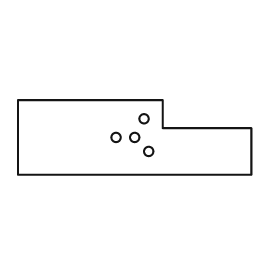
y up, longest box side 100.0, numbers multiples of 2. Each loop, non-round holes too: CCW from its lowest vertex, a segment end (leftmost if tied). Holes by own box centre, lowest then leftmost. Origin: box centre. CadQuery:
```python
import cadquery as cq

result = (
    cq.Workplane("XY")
    .moveTo(-50.0, -16.0)
    .lineTo(50.0, -16.0)
    .lineTo(50.0, 4.0)
    .lineTo(12.0, 4.0)
    .lineTo(12.0, 16.0)
    .lineTo(-50.0, 16.0)
    .close()
    .moveTo(6.0, -6.0)
    .circle(2.0)
    .moveTo(-8.0, 0.0)
    .circle(2.0)
    .moveTo(0.0, 0.0)
    .circle(2.0)
    .moveTo(4.0, 8.0)
    .circle(2.0)
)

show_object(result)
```